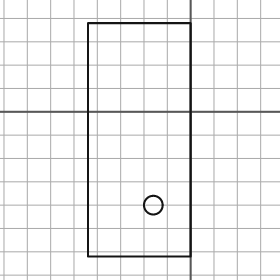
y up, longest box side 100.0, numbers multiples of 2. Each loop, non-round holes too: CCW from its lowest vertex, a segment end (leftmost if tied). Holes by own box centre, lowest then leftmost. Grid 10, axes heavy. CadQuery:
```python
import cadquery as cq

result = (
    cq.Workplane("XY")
    .moveTo(-44.0, -62.0)
    .lineTo(0.0, -62.0)
    .lineTo(0.0, 38.0)
    .lineTo(-44.0, 38.0)
    .close()
    .moveTo(-16.0, -40.0)
    .circle(4.0)
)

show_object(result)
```